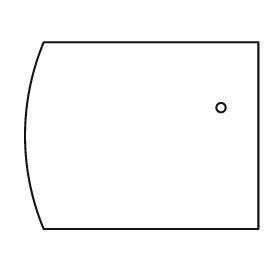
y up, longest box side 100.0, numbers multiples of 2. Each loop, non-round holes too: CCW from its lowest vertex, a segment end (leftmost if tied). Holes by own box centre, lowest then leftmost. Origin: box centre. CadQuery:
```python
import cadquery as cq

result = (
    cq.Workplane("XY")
    .moveTo(-42.0, -40.0)
    .lineTo(50.0, -40.0)
    .lineTo(50.0, 40.0)
    .lineTo(-42.0, 40.0)
    .threePointArc((-50.0, 0.0), (-42.0, -40.0))
    .close()
    .moveTo(34.0, 12.0)
    .circle(2.0)
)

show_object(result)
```